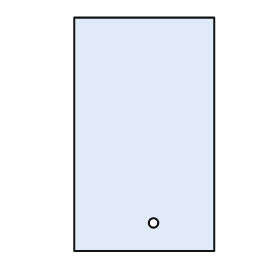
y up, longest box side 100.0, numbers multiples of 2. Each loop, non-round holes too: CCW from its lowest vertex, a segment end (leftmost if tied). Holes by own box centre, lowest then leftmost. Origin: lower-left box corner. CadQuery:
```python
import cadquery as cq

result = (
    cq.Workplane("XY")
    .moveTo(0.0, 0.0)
    .lineTo(60.0, 0.0)
    .lineTo(60.0, 100.0)
    .lineTo(0.0, 100.0)
    .close()
    .moveTo(34.0, 12.0)
    .circle(2.0)
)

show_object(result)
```